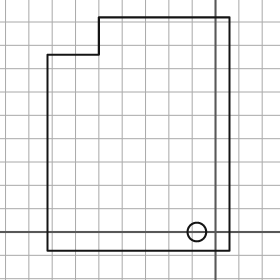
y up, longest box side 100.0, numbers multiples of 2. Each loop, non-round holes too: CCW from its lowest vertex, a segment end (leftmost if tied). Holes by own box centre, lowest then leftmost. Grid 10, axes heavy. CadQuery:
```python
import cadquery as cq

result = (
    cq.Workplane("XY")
    .moveTo(-72.0, -8.0)
    .lineTo(6.0, -8.0)
    .lineTo(6.0, 92.0)
    .lineTo(-50.0, 92.0)
    .lineTo(-50.0, 76.0)
    .lineTo(-72.0, 76.0)
    .close()
    .moveTo(-8.0, 0.0)
    .circle(4.0)
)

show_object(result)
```